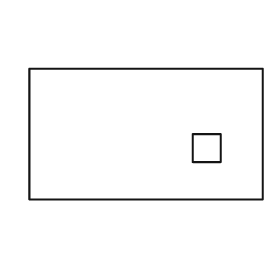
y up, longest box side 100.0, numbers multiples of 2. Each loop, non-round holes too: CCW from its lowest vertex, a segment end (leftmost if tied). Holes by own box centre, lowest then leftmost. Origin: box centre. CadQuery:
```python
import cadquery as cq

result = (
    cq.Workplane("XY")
    .moveTo(-50.0, -28.0)
    .lineTo(50.0, -28.0)
    .lineTo(50.0, 28.0)
    .lineTo(-50.0, 28.0)
    .close()
    .moveTo(20.0, -12.0)
    .lineTo(32.0, -12.0)
    .lineTo(32.0, 0.0)
    .lineTo(20.0, 0.0)
    .close()
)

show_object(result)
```